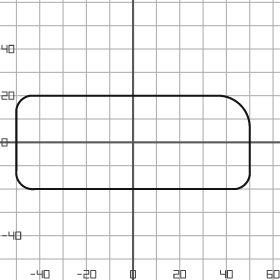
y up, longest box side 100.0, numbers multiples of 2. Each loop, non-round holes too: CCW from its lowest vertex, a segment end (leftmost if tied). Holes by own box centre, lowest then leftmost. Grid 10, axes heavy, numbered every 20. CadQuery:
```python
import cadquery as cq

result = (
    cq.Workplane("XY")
    .moveTo(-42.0, -20.0)
    .lineTo(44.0, -20.0)
    .threePointArc((48.0, -18.0), (50.0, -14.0))
    .lineTo(50.0, 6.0)
    .threePointArc((46.0, 16.0), (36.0, 20.0))
    .lineTo(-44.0, 20.0)
    .threePointArc((-48.0, 18.0), (-50.0, 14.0))
    .lineTo(-50.0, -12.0)
    .threePointArc((-48.0, -18.0), (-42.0, -20.0))
    .close()
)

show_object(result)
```